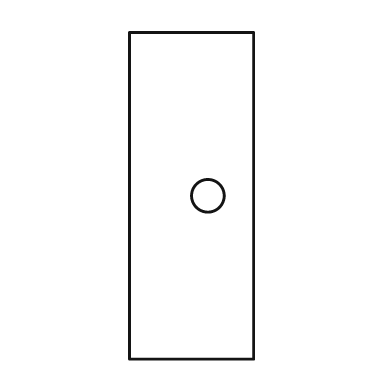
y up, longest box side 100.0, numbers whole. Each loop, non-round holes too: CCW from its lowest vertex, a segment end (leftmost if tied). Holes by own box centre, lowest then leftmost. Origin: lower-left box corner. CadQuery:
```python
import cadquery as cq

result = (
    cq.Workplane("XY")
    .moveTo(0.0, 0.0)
    .lineTo(38.0, 0.0)
    .lineTo(38.0, 100.0)
    .lineTo(0.0, 100.0)
    .close()
    .moveTo(24.0, 50.0)
    .circle(5.0)
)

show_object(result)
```